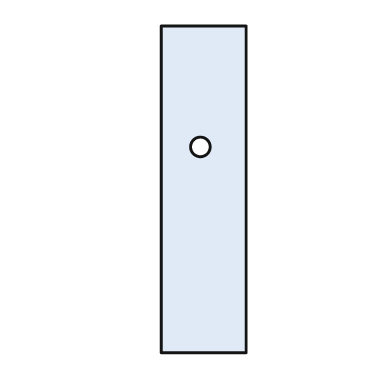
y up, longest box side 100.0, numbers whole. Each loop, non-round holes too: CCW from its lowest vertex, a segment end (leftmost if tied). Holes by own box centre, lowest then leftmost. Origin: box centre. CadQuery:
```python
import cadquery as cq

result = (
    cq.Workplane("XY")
    .moveTo(-13.0, -50.0)
    .lineTo(13.0, -50.0)
    .lineTo(13.0, 50.0)
    .lineTo(-13.0, 50.0)
    .close()
    .moveTo(-1.0, 13.0)
    .circle(3.0)
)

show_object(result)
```